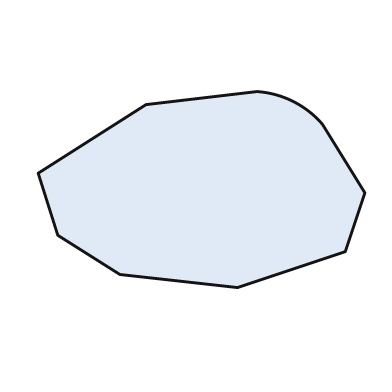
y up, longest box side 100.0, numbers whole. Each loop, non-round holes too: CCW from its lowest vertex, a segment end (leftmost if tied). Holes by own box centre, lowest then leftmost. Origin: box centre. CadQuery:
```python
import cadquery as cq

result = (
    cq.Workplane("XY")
    .moveTo(11.0, -30.0)
    .lineTo(44.0, -19.0)
    .lineTo(50.0, -1.0)
    .lineTo(37.0, 20.0)
    .threePointArc((28.0, 27.0), (17.0, 30.0))
    .lineTo(-17.0, 26.0)
    .lineTo(-50.0, 5.0)
    .lineTo(-44.0, -14.0)
    .lineTo(-25.0, -26.0)
    .close()
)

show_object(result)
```